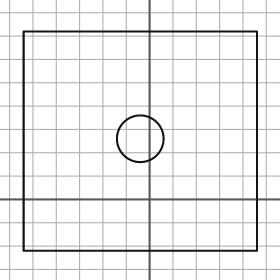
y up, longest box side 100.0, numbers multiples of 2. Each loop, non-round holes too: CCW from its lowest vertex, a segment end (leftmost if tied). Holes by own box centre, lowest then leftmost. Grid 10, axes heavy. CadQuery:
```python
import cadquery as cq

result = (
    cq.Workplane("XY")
    .moveTo(-54.0, -22.0)
    .lineTo(46.0, -22.0)
    .lineTo(46.0, 72.0)
    .lineTo(-54.0, 72.0)
    .close()
    .moveTo(-4.0, 26.0)
    .circle(10.0)
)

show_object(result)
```